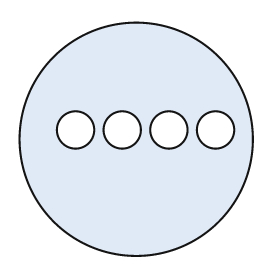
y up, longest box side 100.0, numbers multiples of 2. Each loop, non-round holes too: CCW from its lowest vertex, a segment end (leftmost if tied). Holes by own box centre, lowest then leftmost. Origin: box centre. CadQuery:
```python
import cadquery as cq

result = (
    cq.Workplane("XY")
    .moveTo(0.0, 0.0)
    .circle(50.0)
    .moveTo(-26.0, 4.0)
    .circle(8.0)
    .moveTo(-6.0, 4.0)
    .circle(8.0)
    .moveTo(14.0, 4.0)
    .circle(8.0)
    .moveTo(34.0, 4.0)
    .circle(8.0)
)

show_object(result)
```